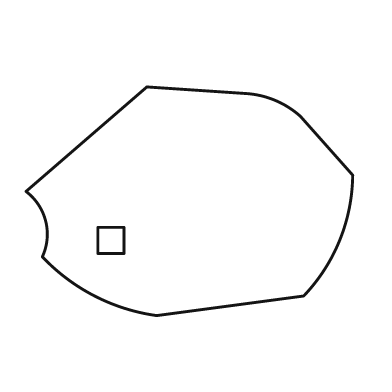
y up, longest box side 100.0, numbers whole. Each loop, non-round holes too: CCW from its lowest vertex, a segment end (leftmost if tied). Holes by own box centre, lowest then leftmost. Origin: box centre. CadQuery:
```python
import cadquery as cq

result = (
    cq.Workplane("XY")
    .moveTo(-10.0, -35.0)
    .lineTo(35.0, -29.0)
    .threePointArc((46.0, -12.0), (50.0, 8.0))
    .lineTo(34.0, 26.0)
    .threePointArc((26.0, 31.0), (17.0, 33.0))
    .lineTo(-13.0, 35.0)
    .lineTo(-50.0, 3.0)
    .threePointArc((-44.0, -6.0), (-45.0, -17.0))
    .threePointArc((-29.0, -29.0), (-10.0, -35.0))
    .close()
    .moveTo(-28.0, -16.0)
    .lineTo(-20.0, -16.0)
    .lineTo(-20.0, -8.0)
    .lineTo(-28.0, -8.0)
    .close()
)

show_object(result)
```